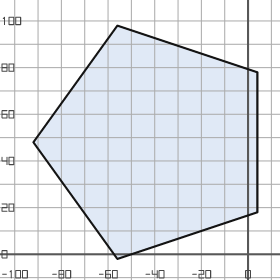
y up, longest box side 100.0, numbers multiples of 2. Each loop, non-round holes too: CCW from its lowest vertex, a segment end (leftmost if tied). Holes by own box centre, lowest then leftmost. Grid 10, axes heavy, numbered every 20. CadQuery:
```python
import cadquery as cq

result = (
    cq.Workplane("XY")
    .moveTo(-56.0, -2.0)
    .lineTo(4.0, 18.0)
    .lineTo(4.0, 78.0)
    .lineTo(-56.0, 98.0)
    .lineTo(-92.0, 48.0)
    .close()
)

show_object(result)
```